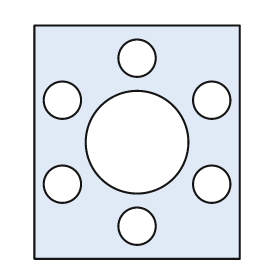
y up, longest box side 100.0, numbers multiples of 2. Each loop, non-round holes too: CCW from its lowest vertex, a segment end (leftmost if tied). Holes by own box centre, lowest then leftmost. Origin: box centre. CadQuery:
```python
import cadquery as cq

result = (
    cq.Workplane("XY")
    .moveTo(-44.0, -50.0)
    .lineTo(44.0, -50.0)
    .lineTo(44.0, 50.0)
    .lineTo(-44.0, 50.0)
    .close()
    .moveTo(0.0, -36.0)
    .circle(8.0)
    .moveTo(-32.0, -18.0)
    .circle(8.0)
    .moveTo(32.0, -18.0)
    .circle(8.0)
    .moveTo(0.0, 0.0)
    .circle(22.0)
    .moveTo(-32.0, 18.0)
    .circle(8.0)
    .moveTo(32.0, 18.0)
    .circle(8.0)
    .moveTo(0.0, 36.0)
    .circle(8.0)
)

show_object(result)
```